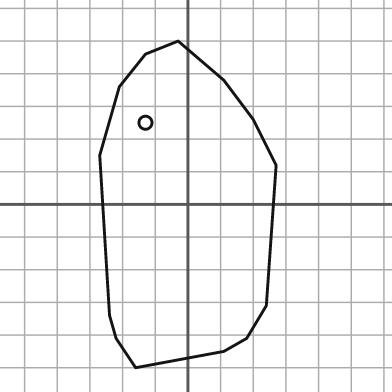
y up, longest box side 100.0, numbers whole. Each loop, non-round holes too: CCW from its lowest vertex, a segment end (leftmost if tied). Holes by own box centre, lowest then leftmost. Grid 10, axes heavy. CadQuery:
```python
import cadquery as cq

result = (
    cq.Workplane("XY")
    .moveTo(-16.0, -50.0)
    .lineTo(11.0, -45.0)
    .lineTo(18.0, -41.0)
    .lineTo(24.0, -31.0)
    .lineTo(27.0, 12.0)
    .lineTo(20.0, 26.0)
    .lineTo(11.0, 38.0)
    .lineTo(-3.0, 50.0)
    .lineTo(-13.0, 46.0)
    .lineTo(-21.0, 36.0)
    .lineTo(-27.0, 15.0)
    .lineTo(-24.0, -34.0)
    .lineTo(-22.0, -41.0)
    .close()
    .moveTo(-13.0, 25.0)
    .circle(2.0)
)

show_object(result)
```